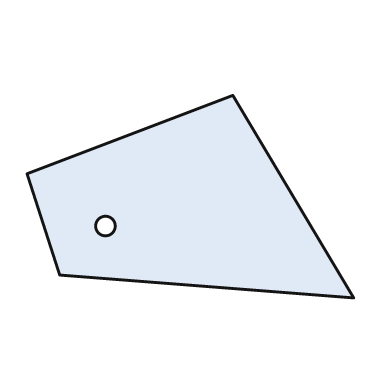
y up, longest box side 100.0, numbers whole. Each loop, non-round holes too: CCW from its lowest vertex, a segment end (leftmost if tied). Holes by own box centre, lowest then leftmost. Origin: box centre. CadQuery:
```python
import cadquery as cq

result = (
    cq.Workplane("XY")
    .moveTo(50.0, -31.0)
    .lineTo(13.0, 31.0)
    .lineTo(-50.0, 7.0)
    .lineTo(-40.0, -24.0)
    .close()
    .moveTo(-26.0, -9.0)
    .circle(3.0)
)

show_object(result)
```